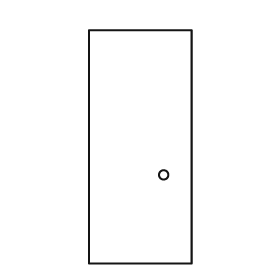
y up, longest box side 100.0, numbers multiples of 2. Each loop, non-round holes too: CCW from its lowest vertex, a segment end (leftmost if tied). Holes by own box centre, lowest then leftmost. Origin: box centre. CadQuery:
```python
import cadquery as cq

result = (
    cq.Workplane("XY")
    .moveTo(-22.0, -50.0)
    .lineTo(22.0, -50.0)
    .lineTo(22.0, 50.0)
    .lineTo(-22.0, 50.0)
    .close()
    .moveTo(10.0, -12.0)
    .circle(2.0)
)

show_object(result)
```